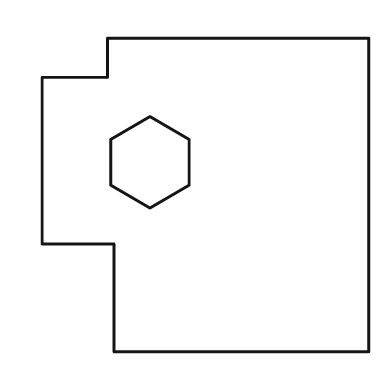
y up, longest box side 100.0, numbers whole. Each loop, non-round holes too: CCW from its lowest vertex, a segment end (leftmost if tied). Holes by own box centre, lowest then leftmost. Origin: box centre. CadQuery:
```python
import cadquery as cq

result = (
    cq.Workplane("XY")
    .moveTo(-28.0, -48.0)
    .lineTo(50.0, -48.0)
    .lineTo(50.0, 48.0)
    .lineTo(-30.0, 48.0)
    .lineTo(-30.0, 36.0)
    .lineTo(-50.0, 36.0)
    .lineTo(-50.0, -15.0)
    .lineTo(-28.0, -15.0)
    .close()
    .moveTo(-17.0, -4.0)
    .lineTo(-5.0, 3.0)
    .lineTo(-5.0, 17.0)
    .lineTo(-17.0, 24.0)
    .lineTo(-29.0, 17.0)
    .lineTo(-29.0, 3.0)
    .close()
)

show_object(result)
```